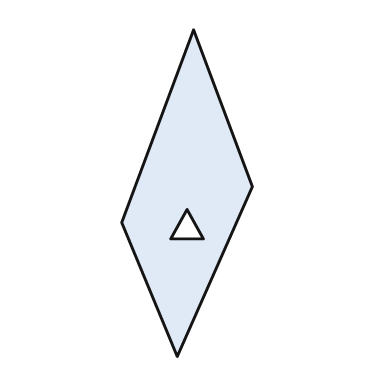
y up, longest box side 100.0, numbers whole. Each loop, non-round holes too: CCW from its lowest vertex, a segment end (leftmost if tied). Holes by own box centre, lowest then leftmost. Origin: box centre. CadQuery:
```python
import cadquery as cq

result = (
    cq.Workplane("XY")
    .moveTo(-3.0, -50.0)
    .lineTo(20.0, 2.0)
    .lineTo(2.0, 50.0)
    .lineTo(-20.0, -9.0)
    .close()
    .moveTo(-5.0, -14.0)
    .lineTo(5.0, -14.0)
    .lineTo(0.0, -5.0)
    .close()
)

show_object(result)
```